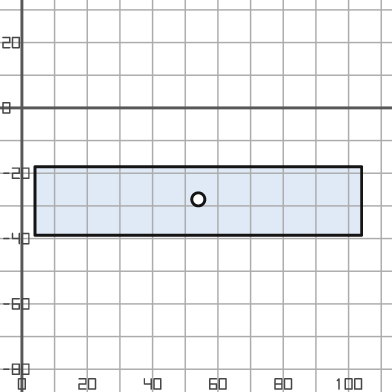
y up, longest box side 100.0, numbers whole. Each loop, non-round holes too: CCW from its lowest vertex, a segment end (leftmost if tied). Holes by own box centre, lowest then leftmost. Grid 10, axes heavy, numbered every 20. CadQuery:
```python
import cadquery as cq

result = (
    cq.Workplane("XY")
    .moveTo(4.0, -39.0)
    .lineTo(104.0, -39.0)
    .lineTo(104.0, -18.0)
    .lineTo(4.0, -18.0)
    .close()
    .moveTo(54.0, -28.0)
    .circle(2.0)
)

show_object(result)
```